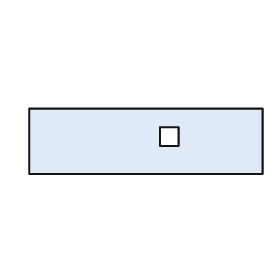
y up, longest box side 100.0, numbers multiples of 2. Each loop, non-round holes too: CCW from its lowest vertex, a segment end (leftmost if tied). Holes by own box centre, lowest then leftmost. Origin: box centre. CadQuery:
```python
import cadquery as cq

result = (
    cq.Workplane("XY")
    .moveTo(-50.0, -14.0)
    .lineTo(50.0, -14.0)
    .lineTo(50.0, 14.0)
    .lineTo(-50.0, 14.0)
    .close()
    .moveTo(6.0, -2.0)
    .lineTo(14.0, -2.0)
    .lineTo(14.0, 6.0)
    .lineTo(6.0, 6.0)
    .close()
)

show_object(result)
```